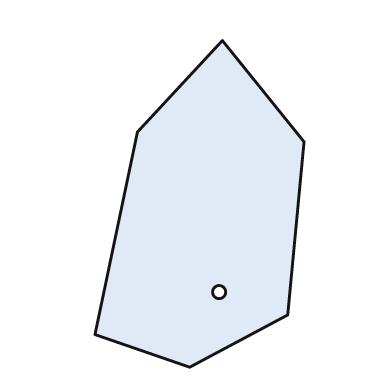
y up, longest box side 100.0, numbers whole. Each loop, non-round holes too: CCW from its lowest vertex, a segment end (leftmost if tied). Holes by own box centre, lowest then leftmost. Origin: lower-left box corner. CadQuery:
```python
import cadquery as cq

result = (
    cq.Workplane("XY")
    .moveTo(29.0, 0.0)
    .lineTo(59.0, 16.0)
    .lineTo(64.0, 69.0)
    .lineTo(39.0, 100.0)
    .lineTo(13.0, 72.0)
    .lineTo(0.0, 10.0)
    .close()
    .moveTo(38.0, 23.0)
    .circle(2.0)
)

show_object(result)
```